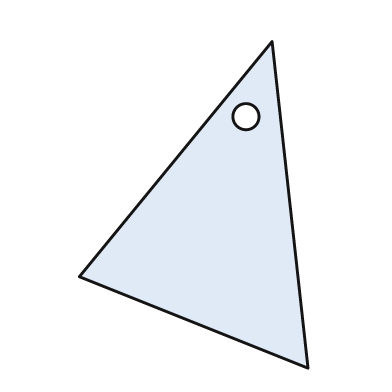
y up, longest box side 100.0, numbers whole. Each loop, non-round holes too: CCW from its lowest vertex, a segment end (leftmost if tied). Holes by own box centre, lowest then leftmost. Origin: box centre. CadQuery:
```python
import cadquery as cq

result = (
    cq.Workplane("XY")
    .moveTo(35.0, -50.0)
    .lineTo(24.0, 50.0)
    .lineTo(-35.0, -22.0)
    .close()
    .moveTo(16.0, 27.0)
    .circle(4.0)
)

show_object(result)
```